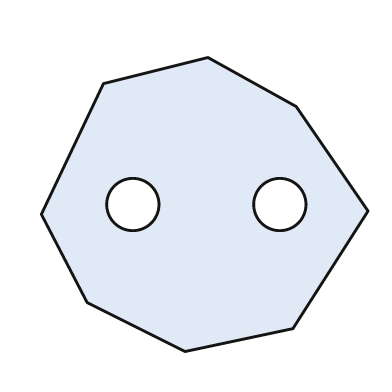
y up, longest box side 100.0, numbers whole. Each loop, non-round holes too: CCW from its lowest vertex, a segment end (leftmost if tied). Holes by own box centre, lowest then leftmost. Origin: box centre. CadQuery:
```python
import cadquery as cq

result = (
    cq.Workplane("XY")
    .moveTo(-6.0, -45.0)
    .lineTo(27.0, -38.0)
    .lineTo(50.0, -2.0)
    .lineTo(28.0, 30.0)
    .lineTo(1.0, 45.0)
    .lineTo(-31.0, 37.0)
    .lineTo(-50.0, -3.0)
    .lineTo(-36.0, -30.0)
    .close()
    .moveTo(-22.0, 0.0)
    .circle(8.0)
    .moveTo(23.0, 0.0)
    .circle(8.0)
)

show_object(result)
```